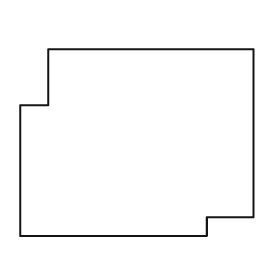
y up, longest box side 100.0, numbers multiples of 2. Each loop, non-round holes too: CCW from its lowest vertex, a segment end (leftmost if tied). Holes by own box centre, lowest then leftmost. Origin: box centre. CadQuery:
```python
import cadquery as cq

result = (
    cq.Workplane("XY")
    .moveTo(-50.0, -40.0)
    .lineTo(30.0, -40.0)
    .lineTo(30.0, -32.0)
    .lineTo(50.0, -32.0)
    .lineTo(50.0, 40.0)
    .lineTo(-38.0, 40.0)
    .lineTo(-38.0, 16.0)
    .lineTo(-50.0, 16.0)
    .close()
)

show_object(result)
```